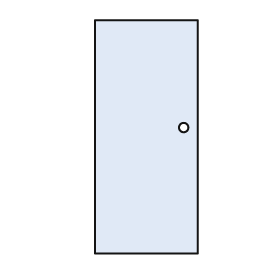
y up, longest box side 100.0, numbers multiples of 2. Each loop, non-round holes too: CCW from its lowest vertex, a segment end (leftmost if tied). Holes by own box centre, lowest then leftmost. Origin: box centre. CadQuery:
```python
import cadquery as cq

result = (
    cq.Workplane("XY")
    .moveTo(-22.0, -50.0)
    .lineTo(22.0, -50.0)
    .lineTo(22.0, 50.0)
    .lineTo(-22.0, 50.0)
    .close()
    .moveTo(16.0, 4.0)
    .circle(2.0)
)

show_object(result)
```